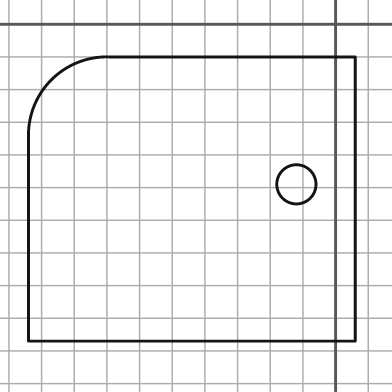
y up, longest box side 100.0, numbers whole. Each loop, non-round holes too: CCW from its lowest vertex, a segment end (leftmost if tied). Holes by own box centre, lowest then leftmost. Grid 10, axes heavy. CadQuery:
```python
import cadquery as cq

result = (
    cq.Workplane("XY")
    .moveTo(-94.0, -97.0)
    .lineTo(6.0, -97.0)
    .lineTo(6.0, -10.0)
    .lineTo(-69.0, -10.0)
    .threePointArc((-87.0, -17.0), (-94.0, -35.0))
    .close()
    .moveTo(-12.0, -49.0)
    .circle(6.0)
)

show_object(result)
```